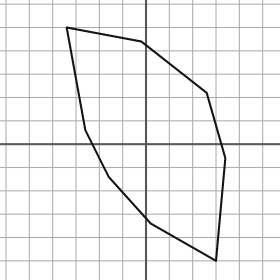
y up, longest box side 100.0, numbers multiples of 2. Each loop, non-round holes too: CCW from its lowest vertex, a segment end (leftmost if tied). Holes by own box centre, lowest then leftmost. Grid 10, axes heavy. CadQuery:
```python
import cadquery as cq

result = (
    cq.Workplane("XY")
    .moveTo(30.0, -50.0)
    .lineTo(34.0, -6.0)
    .lineTo(26.0, 22.0)
    .lineTo(-2.0, 44.0)
    .lineTo(-34.0, 50.0)
    .lineTo(-26.0, 6.0)
    .lineTo(-16.0, -14.0)
    .lineTo(2.0, -34.0)
    .close()
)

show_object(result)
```